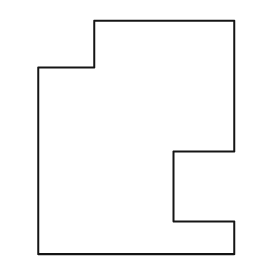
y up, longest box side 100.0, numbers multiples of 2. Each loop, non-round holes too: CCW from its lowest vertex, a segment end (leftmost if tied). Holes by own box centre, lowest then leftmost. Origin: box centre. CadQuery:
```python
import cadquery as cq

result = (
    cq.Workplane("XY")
    .moveTo(-42.0, -50.0)
    .lineTo(42.0, -50.0)
    .lineTo(42.0, -36.0)
    .lineTo(16.0, -36.0)
    .lineTo(16.0, -6.0)
    .lineTo(42.0, -6.0)
    .lineTo(42.0, 50.0)
    .lineTo(-18.0, 50.0)
    .lineTo(-18.0, 30.0)
    .lineTo(-42.0, 30.0)
    .close()
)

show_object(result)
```